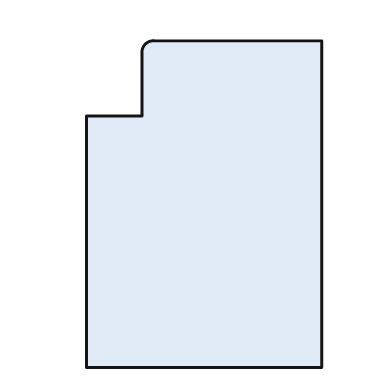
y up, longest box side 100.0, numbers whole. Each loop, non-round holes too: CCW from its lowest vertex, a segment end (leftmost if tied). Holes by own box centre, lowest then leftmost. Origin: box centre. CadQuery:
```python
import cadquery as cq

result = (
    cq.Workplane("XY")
    .moveTo(-36.0, -50.0)
    .lineTo(36.0, -50.0)
    .lineTo(36.0, 50.0)
    .lineTo(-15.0, 50.0)
    .threePointArc((-18.0, 49.0), (-19.0, 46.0))
    .lineTo(-19.0, 27.0)
    .lineTo(-36.0, 27.0)
    .close()
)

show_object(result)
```